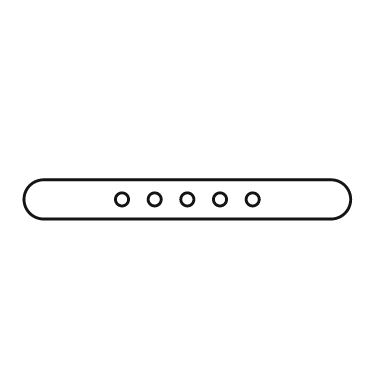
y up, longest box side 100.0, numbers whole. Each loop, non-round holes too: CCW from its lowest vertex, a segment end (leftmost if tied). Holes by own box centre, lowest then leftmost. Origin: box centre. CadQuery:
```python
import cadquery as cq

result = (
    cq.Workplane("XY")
    .moveTo(-44.0, -6.0)
    .lineTo(44.0, -6.0)
    .threePointArc((50.0, 0.0), (44.0, 6.0))
    .lineTo(-44.0, 6.0)
    .threePointArc((-50.0, 0.0), (-44.0, -6.0))
    .close()
    .moveTo(-20.0, 0.0)
    .circle(2.0)
    .moveTo(-10.0, 0.0)
    .circle(2.0)
    .moveTo(0.0, 0.0)
    .circle(2.0)
    .moveTo(10.0, 0.0)
    .circle(2.0)
    .moveTo(20.0, 0.0)
    .circle(2.0)
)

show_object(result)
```